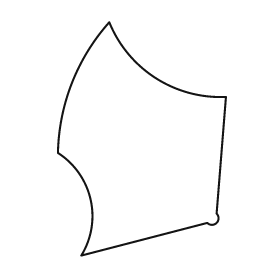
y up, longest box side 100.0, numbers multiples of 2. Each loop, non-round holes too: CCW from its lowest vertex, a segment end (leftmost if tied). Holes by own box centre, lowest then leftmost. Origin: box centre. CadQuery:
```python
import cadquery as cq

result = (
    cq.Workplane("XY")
    .moveTo(-26.0, -50.0)
    .lineTo(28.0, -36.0)
    .threePointArc((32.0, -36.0), (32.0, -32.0))
    .lineTo(36.0, 18.0)
    .threePointArc((6.0, 26.0), (-14.0, 50.0))
    .threePointArc((-30.0, 24.0), (-36.0, -6.0))
    .threePointArc((-22.0, -26.0), (-26.0, -50.0))
    .close()
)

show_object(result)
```